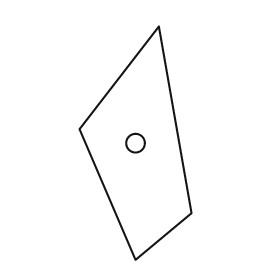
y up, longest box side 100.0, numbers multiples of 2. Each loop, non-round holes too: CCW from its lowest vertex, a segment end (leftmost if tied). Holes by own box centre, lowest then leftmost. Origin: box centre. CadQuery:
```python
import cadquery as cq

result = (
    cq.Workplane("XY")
    .moveTo(0.0, -50.0)
    .lineTo(24.0, -30.0)
    .lineTo(10.0, 50.0)
    .lineTo(-24.0, 6.0)
    .close()
    .moveTo(0.0, 0.0)
    .circle(4.0)
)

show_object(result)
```